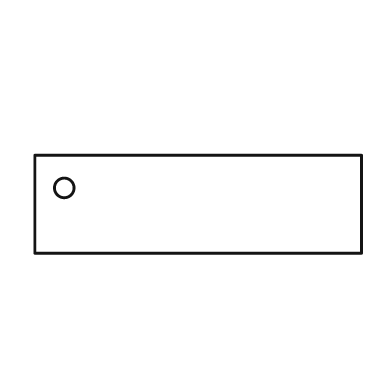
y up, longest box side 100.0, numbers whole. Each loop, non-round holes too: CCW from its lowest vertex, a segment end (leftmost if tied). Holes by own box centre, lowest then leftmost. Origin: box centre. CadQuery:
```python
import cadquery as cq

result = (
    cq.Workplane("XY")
    .moveTo(-50.0, -15.0)
    .lineTo(50.0, -15.0)
    .lineTo(50.0, 15.0)
    .lineTo(-50.0, 15.0)
    .close()
    .moveTo(-41.0, 5.0)
    .circle(3.0)
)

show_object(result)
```